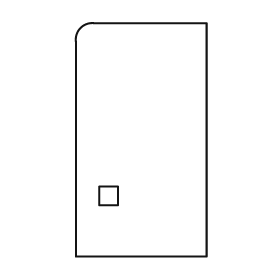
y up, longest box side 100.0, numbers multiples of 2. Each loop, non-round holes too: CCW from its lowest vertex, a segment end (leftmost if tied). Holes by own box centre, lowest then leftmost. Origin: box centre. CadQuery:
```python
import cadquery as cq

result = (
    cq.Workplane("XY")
    .moveTo(-28.0, -50.0)
    .lineTo(28.0, -50.0)
    .lineTo(28.0, 50.0)
    .lineTo(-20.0, 50.0)
    .threePointArc((-26.0, 48.0), (-28.0, 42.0))
    .close()
    .moveTo(-18.0, -28.0)
    .lineTo(-10.0, -28.0)
    .lineTo(-10.0, -20.0)
    .lineTo(-18.0, -20.0)
    .close()
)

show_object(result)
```